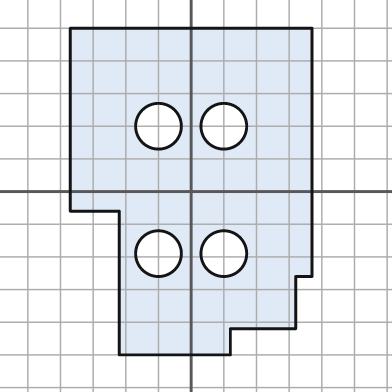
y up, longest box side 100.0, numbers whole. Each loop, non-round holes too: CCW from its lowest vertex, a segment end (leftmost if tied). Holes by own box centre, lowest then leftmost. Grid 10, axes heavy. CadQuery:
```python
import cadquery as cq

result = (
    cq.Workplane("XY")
    .moveTo(-22.0, -50.0)
    .lineTo(12.0, -50.0)
    .lineTo(12.0, -42.0)
    .lineTo(32.0, -42.0)
    .lineTo(32.0, -26.0)
    .lineTo(37.0, -26.0)
    .lineTo(37.0, 50.0)
    .lineTo(-37.0, 50.0)
    .lineTo(-37.0, -6.0)
    .lineTo(-22.0, -6.0)
    .close()
    .moveTo(-10.0, -19.0)
    .circle(7.0)
    .moveTo(10.0, -19.0)
    .circle(7.0)
    .moveTo(-10.0, 20.0)
    .circle(7.0)
    .moveTo(10.0, 20.0)
    .circle(7.0)
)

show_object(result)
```